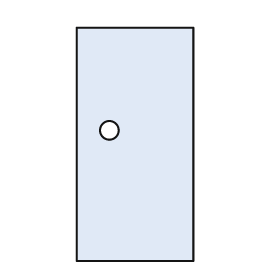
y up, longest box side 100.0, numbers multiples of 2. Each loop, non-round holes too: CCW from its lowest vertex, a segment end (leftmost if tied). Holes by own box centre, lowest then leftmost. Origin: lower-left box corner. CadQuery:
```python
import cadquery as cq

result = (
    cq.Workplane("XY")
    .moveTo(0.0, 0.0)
    .lineTo(50.0, 0.0)
    .lineTo(50.0, 100.0)
    .lineTo(0.0, 100.0)
    .close()
    .moveTo(14.0, 56.0)
    .circle(4.0)
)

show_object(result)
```